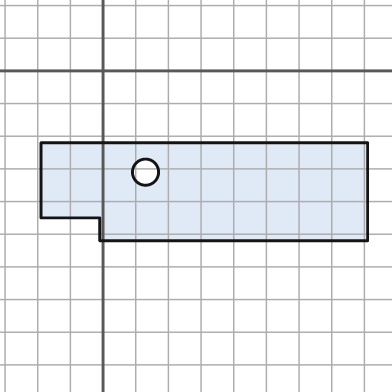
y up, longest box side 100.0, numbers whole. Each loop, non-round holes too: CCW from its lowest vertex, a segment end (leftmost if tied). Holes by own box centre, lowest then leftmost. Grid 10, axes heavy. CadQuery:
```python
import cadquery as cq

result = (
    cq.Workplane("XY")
    .moveTo(-1.0, -52.0)
    .lineTo(81.0, -52.0)
    .lineTo(81.0, -22.0)
    .lineTo(-19.0, -22.0)
    .lineTo(-19.0, -45.0)
    .lineTo(-1.0, -45.0)
    .close()
    .moveTo(13.0, -31.0)
    .circle(4.0)
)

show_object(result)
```